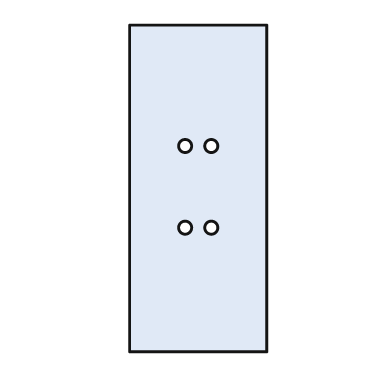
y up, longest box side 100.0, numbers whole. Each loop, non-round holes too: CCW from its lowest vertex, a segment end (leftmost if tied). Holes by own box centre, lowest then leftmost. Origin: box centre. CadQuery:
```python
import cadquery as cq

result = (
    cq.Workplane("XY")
    .moveTo(-21.0, -50.0)
    .lineTo(21.0, -50.0)
    .lineTo(21.0, 50.0)
    .lineTo(-21.0, 50.0)
    .close()
    .moveTo(-4.0, -12.0)
    .circle(2.0)
    .moveTo(4.0, -12.0)
    .circle(2.0)
    .moveTo(-4.0, 13.0)
    .circle(2.0)
    .moveTo(4.0, 13.0)
    .circle(2.0)
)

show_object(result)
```